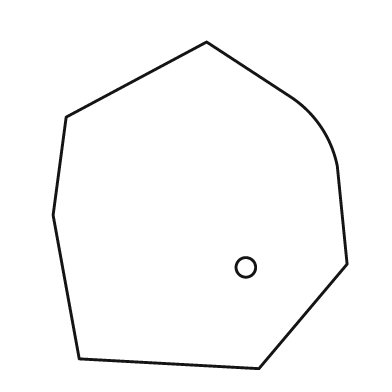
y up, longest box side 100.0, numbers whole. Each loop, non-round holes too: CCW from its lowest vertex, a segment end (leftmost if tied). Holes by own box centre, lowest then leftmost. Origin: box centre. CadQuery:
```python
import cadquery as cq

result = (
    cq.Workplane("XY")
    .moveTo(18.0, -50.0)
    .lineTo(45.0, -18.0)
    .lineTo(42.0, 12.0)
    .threePointArc((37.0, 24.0), (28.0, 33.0))
    .lineTo(2.0, 50.0)
    .lineTo(-41.0, 27.0)
    .lineTo(-45.0, -3.0)
    .lineTo(-37.0, -47.0)
    .close()
    .moveTo(14.0, -19.0)
    .circle(3.0)
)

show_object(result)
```